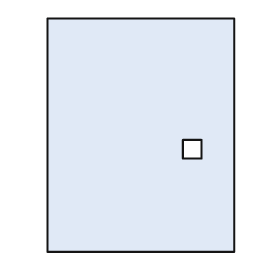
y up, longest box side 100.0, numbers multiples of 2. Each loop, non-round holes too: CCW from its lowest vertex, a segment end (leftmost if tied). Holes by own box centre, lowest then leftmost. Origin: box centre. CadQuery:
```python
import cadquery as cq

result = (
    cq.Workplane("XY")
    .moveTo(-40.0, -50.0)
    .lineTo(40.0, -50.0)
    .lineTo(40.0, 50.0)
    .lineTo(-40.0, 50.0)
    .close()
    .moveTo(18.0, -10.0)
    .lineTo(26.0, -10.0)
    .lineTo(26.0, -2.0)
    .lineTo(18.0, -2.0)
    .close()
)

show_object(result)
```